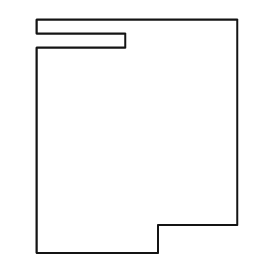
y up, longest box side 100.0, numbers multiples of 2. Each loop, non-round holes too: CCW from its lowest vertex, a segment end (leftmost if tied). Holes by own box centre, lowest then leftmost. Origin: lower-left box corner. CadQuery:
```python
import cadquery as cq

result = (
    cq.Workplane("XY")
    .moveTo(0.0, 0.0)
    .lineTo(52.0, 0.0)
    .lineTo(52.0, 12.0)
    .lineTo(86.0, 12.0)
    .lineTo(86.0, 100.0)
    .lineTo(0.0, 100.0)
    .lineTo(0.0, 94.0)
    .lineTo(38.0, 94.0)
    .lineTo(38.0, 88.0)
    .lineTo(0.0, 88.0)
    .close()
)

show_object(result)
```